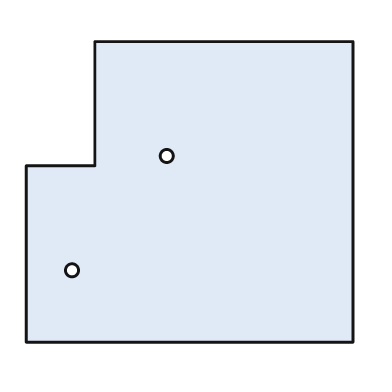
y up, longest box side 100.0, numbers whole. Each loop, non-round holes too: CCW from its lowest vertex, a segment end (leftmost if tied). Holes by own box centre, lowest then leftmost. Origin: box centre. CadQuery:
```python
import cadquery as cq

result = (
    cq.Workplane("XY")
    .moveTo(-50.0, -46.0)
    .lineTo(50.0, -46.0)
    .lineTo(50.0, 46.0)
    .lineTo(-29.0, 46.0)
    .lineTo(-29.0, 8.0)
    .lineTo(-50.0, 8.0)
    .close()
    .moveTo(-36.0, -24.0)
    .circle(2.0)
    .moveTo(-7.0, 11.0)
    .circle(2.0)
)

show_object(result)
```